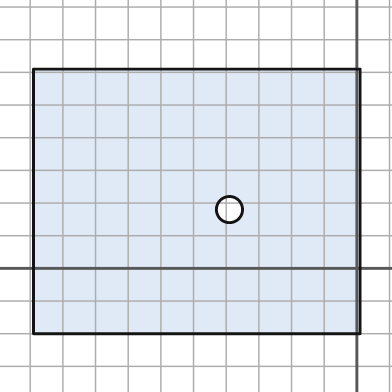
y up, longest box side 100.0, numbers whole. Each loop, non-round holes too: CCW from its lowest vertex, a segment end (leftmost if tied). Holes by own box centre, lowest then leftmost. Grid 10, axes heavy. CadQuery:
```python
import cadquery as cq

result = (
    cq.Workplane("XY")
    .moveTo(-99.0, -20.0)
    .lineTo(1.0, -20.0)
    .lineTo(1.0, 61.0)
    .lineTo(-99.0, 61.0)
    .close()
    .moveTo(-39.0, 18.0)
    .circle(4.0)
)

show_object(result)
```